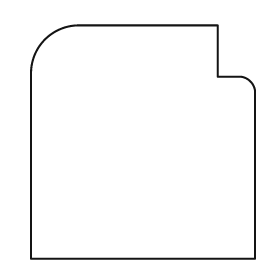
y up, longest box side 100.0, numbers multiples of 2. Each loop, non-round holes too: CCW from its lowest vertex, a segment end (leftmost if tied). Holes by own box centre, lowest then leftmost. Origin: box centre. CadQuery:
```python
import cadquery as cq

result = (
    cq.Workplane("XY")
    .moveTo(-48.0, -50.0)
    .lineTo(48.0, -50.0)
    .lineTo(48.0, 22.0)
    .threePointArc((46.0, 26.0), (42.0, 28.0))
    .lineTo(32.0, 28.0)
    .lineTo(32.0, 50.0)
    .lineTo(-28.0, 50.0)
    .threePointArc((-42.0, 44.0), (-48.0, 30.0))
    .close()
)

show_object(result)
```